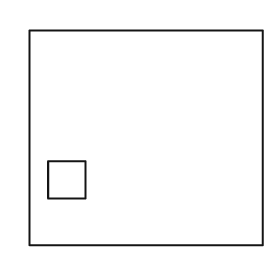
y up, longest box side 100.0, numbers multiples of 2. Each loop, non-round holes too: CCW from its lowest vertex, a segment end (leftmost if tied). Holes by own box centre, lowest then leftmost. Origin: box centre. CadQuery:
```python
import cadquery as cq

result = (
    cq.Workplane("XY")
    .moveTo(-50.0, -46.0)
    .lineTo(50.0, -46.0)
    .lineTo(50.0, 46.0)
    .lineTo(-50.0, 46.0)
    .close()
    .moveTo(-42.0, -26.0)
    .lineTo(-26.0, -26.0)
    .lineTo(-26.0, -10.0)
    .lineTo(-42.0, -10.0)
    .close()
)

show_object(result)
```